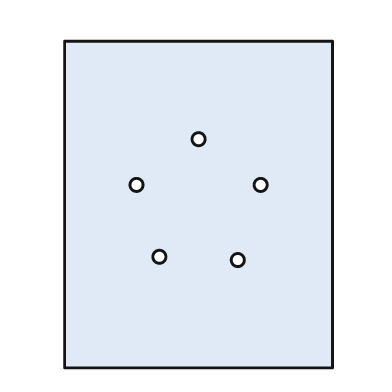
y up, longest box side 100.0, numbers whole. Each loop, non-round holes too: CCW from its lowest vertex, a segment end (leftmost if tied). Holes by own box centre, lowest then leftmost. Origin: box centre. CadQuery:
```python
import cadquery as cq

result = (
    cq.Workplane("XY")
    .moveTo(-41.0, -50.0)
    .lineTo(41.0, -50.0)
    .lineTo(41.0, 50.0)
    .lineTo(-41.0, 50.0)
    .close()
    .moveTo(12.0, -17.0)
    .circle(2.0)
    .moveTo(-12.0, -16.0)
    .circle(2.0)
    .moveTo(-19.0, 6.0)
    .circle(2.0)
    .moveTo(19.0, 6.0)
    .circle(2.0)
    .moveTo(0.0, 20.0)
    .circle(2.0)
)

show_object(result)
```